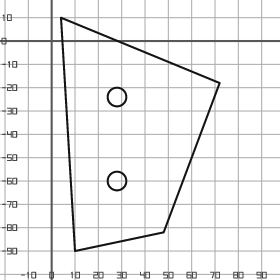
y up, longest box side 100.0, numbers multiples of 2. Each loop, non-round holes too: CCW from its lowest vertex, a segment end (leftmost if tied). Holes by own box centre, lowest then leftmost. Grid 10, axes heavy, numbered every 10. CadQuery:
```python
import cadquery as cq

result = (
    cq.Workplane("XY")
    .moveTo(10.0, -90.0)
    .lineTo(48.0, -82.0)
    .lineTo(72.0, -18.0)
    .lineTo(4.0, 10.0)
    .close()
    .moveTo(28.0, -60.0)
    .circle(4.0)
    .moveTo(28.0, -24.0)
    .circle(4.0)
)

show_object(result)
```